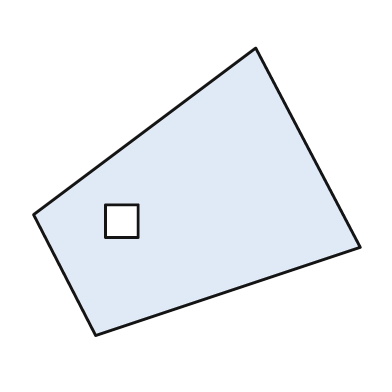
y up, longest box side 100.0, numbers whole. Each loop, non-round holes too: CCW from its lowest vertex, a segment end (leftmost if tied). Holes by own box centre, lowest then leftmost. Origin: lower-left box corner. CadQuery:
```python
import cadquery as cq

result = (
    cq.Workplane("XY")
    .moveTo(19.0, 0.0)
    .lineTo(100.0, 27.0)
    .lineTo(68.0, 88.0)
    .lineTo(0.0, 37.0)
    .close()
    .moveTo(22.0, 30.0)
    .lineTo(32.0, 30.0)
    .lineTo(32.0, 40.0)
    .lineTo(22.0, 40.0)
    .close()
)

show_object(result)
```